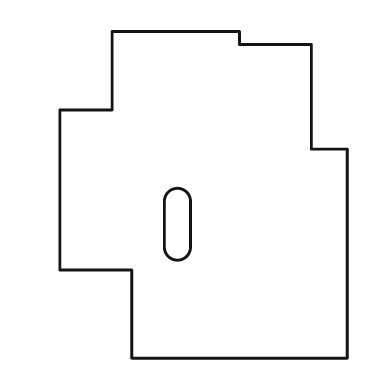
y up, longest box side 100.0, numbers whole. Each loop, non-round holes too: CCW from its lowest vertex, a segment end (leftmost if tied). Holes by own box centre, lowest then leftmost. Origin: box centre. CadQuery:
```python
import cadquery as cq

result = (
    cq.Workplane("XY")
    .moveTo(-22.0, -50.0)
    .lineTo(44.0, -50.0)
    .lineTo(44.0, 14.0)
    .lineTo(33.0, 14.0)
    .lineTo(33.0, 46.0)
    .lineTo(11.0, 46.0)
    .lineTo(11.0, 50.0)
    .lineTo(-28.0, 50.0)
    .lineTo(-28.0, 26.0)
    .lineTo(-44.0, 26.0)
    .lineTo(-44.0, -23.0)
    .lineTo(-22.0, -23.0)
    .close()
    .moveTo(-12.0, -16.0)
    .threePointArc((-8.0, -20.0), (-4.0, -16.0))
    .lineTo(-4.0, -2.0)
    .threePointArc((-8.0, 2.0), (-12.0, -2.0))
    .close()
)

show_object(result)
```